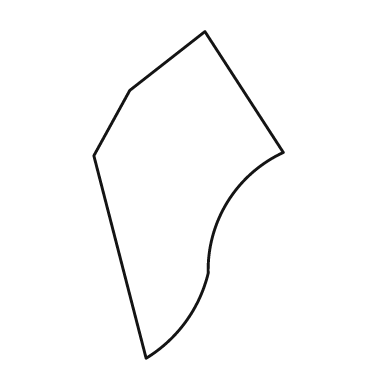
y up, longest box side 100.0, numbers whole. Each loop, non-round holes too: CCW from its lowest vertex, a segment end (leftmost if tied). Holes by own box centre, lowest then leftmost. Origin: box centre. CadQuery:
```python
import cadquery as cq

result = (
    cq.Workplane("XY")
    .moveTo(-13.0, -50.0)
    .threePointArc((-1.0, -39.0), (6.0, -24.0))
    .threePointArc((12.0, -2.0), (29.0, 13.0))
    .lineTo(5.0, 50.0)
    .lineTo(-18.0, 32.0)
    .lineTo(-29.0, 12.0)
    .close()
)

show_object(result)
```